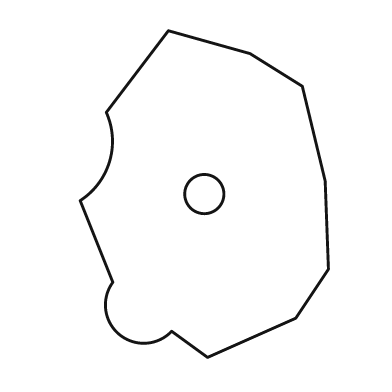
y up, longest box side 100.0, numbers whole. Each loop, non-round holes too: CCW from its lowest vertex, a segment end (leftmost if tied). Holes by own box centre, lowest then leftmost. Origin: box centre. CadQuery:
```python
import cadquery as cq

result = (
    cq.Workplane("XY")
    .moveTo(1.0, -50.0)
    .lineTo(28.0, -38.0)
    .lineTo(38.0, -23.0)
    .lineTo(37.0, 4.0)
    .lineTo(30.0, 33.0)
    .lineTo(14.0, 43.0)
    .lineTo(-11.0, 50.0)
    .lineTo(-30.0, 25.0)
    .threePointArc((-29.0, 10.0), (-38.0, -2.0))
    .lineTo(-28.0, -27.0)
    .threePointArc((-26.0, -43.0), (-10.0, -42.0))
    .close()
    .moveTo(0.0, 0.0)
    .circle(6.0)
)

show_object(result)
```